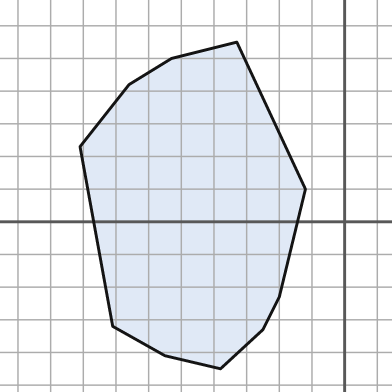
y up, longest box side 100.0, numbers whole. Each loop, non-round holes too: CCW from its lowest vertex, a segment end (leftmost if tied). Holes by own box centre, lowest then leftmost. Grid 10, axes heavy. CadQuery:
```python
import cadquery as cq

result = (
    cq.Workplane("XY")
    .moveTo(-38.0, -45.0)
    .lineTo(-25.0, -33.0)
    .lineTo(-20.0, -23.0)
    .lineTo(-12.0, 10.0)
    .lineTo(-33.0, 55.0)
    .lineTo(-53.0, 50.0)
    .lineTo(-66.0, 42.0)
    .lineTo(-81.0, 23.0)
    .lineTo(-71.0, -32.0)
    .lineTo(-55.0, -41.0)
    .close()
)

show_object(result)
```